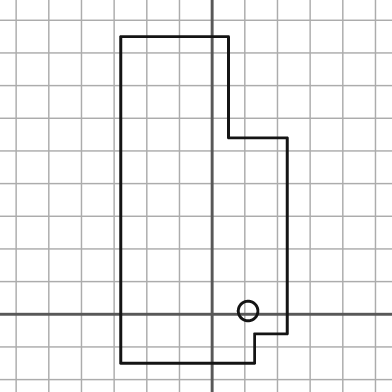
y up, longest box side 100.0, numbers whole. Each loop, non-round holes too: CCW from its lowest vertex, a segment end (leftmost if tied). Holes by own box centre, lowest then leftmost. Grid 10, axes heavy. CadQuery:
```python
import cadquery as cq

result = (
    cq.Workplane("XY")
    .moveTo(-28.0, -15.0)
    .lineTo(13.0, -15.0)
    .lineTo(13.0, -6.0)
    .lineTo(23.0, -6.0)
    .lineTo(23.0, 54.0)
    .lineTo(5.0, 54.0)
    .lineTo(5.0, 85.0)
    .lineTo(-28.0, 85.0)
    .close()
    .moveTo(11.0, 1.0)
    .circle(3.0)
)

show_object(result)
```